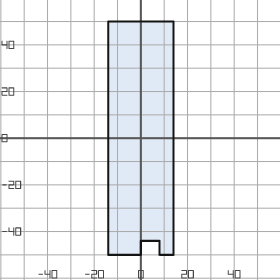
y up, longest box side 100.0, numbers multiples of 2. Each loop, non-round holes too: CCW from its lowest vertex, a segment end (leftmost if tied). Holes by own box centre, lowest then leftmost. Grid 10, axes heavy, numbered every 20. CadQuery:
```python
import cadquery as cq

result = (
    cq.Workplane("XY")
    .moveTo(-14.0, -50.0)
    .lineTo(0.0, -50.0)
    .lineTo(0.0, -44.0)
    .lineTo(8.0, -44.0)
    .lineTo(8.0, -50.0)
    .lineTo(14.0, -50.0)
    .lineTo(14.0, 50.0)
    .lineTo(-14.0, 50.0)
    .close()
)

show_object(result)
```